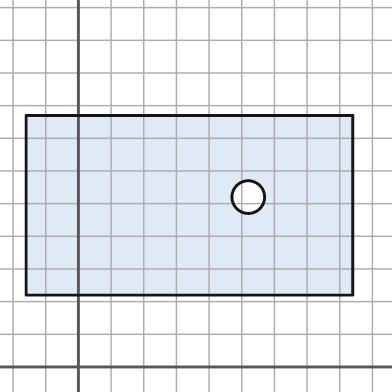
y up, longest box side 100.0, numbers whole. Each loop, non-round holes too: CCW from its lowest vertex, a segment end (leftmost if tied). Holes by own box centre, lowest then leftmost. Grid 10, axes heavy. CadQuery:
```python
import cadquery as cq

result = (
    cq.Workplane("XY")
    .moveTo(-16.0, 22.0)
    .lineTo(84.0, 22.0)
    .lineTo(84.0, 77.0)
    .lineTo(-16.0, 77.0)
    .close()
    .moveTo(52.0, 52.0)
    .circle(5.0)
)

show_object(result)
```